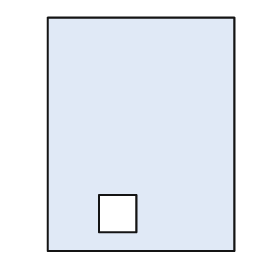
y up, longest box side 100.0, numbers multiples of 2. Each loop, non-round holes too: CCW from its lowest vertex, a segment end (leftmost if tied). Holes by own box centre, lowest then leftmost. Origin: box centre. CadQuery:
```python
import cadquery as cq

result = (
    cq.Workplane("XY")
    .moveTo(-40.0, -50.0)
    .lineTo(40.0, -50.0)
    .lineTo(40.0, 50.0)
    .lineTo(-40.0, 50.0)
    .close()
    .moveTo(-18.0, -42.0)
    .lineTo(-2.0, -42.0)
    .lineTo(-2.0, -26.0)
    .lineTo(-18.0, -26.0)
    .close()
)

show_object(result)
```